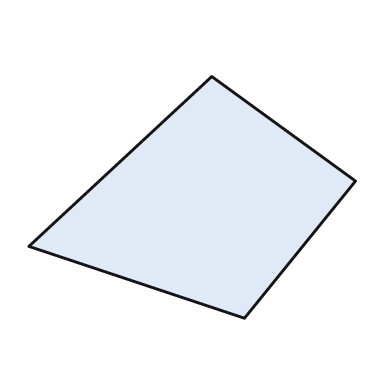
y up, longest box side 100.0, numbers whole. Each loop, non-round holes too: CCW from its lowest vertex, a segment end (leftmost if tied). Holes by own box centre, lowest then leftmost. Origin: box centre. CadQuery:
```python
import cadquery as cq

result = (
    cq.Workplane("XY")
    .moveTo(16.0, -37.0)
    .lineTo(50.0, 5.0)
    .lineTo(6.0, 37.0)
    .lineTo(-50.0, -15.0)
    .close()
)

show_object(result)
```